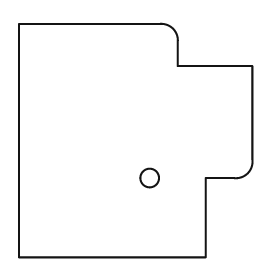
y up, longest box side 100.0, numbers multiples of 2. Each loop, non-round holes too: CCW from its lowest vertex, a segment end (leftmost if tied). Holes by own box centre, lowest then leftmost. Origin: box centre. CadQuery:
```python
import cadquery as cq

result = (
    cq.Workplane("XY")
    .moveTo(-50.0, -50.0)
    .lineTo(30.0, -50.0)
    .lineTo(30.0, -16.0)
    .lineTo(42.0, -16.0)
    .threePointArc((48.0, -14.0), (50.0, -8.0))
    .lineTo(50.0, 32.0)
    .lineTo(18.0, 32.0)
    .lineTo(18.0, 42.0)
    .threePointArc((16.0, 48.0), (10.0, 50.0))
    .lineTo(-50.0, 50.0)
    .close()
    .moveTo(6.0, -16.0)
    .circle(4.0)
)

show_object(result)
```